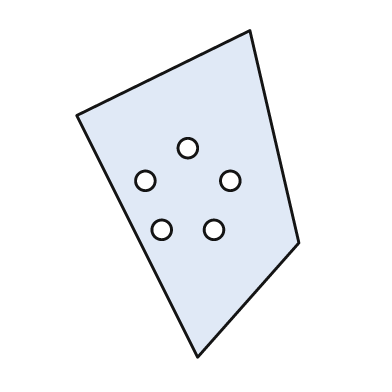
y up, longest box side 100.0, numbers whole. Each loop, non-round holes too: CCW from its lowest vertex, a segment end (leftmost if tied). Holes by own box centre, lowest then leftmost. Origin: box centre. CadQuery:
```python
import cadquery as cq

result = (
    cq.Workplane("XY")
    .moveTo(3.0, -50.0)
    .lineTo(34.0, -15.0)
    .lineTo(19.0, 50.0)
    .lineTo(-34.0, 24.0)
    .close()
    .moveTo(-8.0, -11.0)
    .circle(3.0)
    .moveTo(8.0, -11.0)
    .circle(3.0)
    .moveTo(-13.0, 4.0)
    .circle(3.0)
    .moveTo(13.0, 4.0)
    .circle(3.0)
    .moveTo(0.0, 14.0)
    .circle(3.0)
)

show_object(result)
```